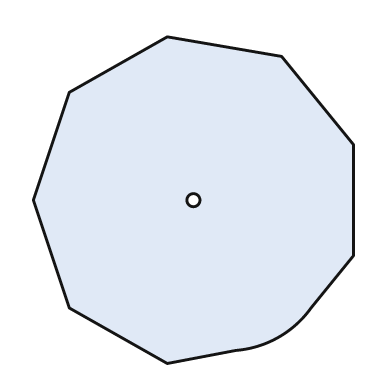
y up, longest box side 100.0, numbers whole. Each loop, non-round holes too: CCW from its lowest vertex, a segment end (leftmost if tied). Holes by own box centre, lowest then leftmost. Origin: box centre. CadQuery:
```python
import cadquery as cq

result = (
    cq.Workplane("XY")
    .moveTo(-8.0, -50.0)
    .lineTo(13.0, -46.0)
    .threePointArc((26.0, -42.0), (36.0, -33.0))
    .lineTo(49.0, -17.0)
    .lineTo(49.0, 17.0)
    .lineTo(27.0, 44.0)
    .lineTo(-8.0, 50.0)
    .lineTo(-38.0, 33.0)
    .lineTo(-49.0, 0.0)
    .lineTo(-38.0, -33.0)
    .close()
    .moveTo(0.0, 0.0)
    .circle(2.0)
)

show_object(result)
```